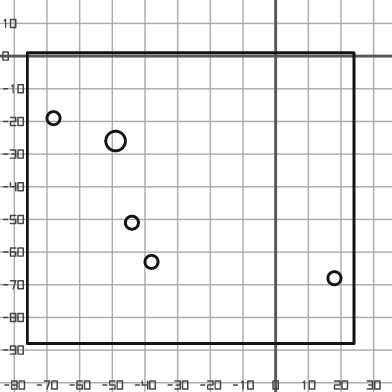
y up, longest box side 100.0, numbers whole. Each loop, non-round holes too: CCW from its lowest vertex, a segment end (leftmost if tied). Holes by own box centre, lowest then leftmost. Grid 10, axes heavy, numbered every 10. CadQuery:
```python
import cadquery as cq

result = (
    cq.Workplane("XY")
    .moveTo(-76.0, -88.0)
    .lineTo(24.0, -88.0)
    .lineTo(24.0, 1.0)
    .lineTo(-76.0, 1.0)
    .close()
    .moveTo(18.0, -68.0)
    .circle(2.0)
    .moveTo(-38.0, -63.0)
    .circle(2.0)
    .moveTo(-44.0, -51.0)
    .circle(2.0)
    .moveTo(-49.0, -26.0)
    .circle(3.0)
    .moveTo(-68.0, -19.0)
    .circle(2.0)
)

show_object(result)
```